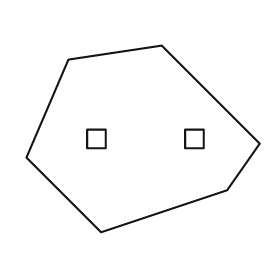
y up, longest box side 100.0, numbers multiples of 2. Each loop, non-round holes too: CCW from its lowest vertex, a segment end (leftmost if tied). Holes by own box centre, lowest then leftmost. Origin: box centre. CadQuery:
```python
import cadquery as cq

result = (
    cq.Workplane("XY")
    .moveTo(-18.0, -40.0)
    .lineTo(36.0, -22.0)
    .lineTo(50.0, -2.0)
    .lineTo(8.0, 40.0)
    .lineTo(-32.0, 34.0)
    .lineTo(-50.0, -8.0)
    .close()
    .moveTo(-24.0, -4.0)
    .lineTo(-16.0, -4.0)
    .lineTo(-16.0, 4.0)
    .lineTo(-24.0, 4.0)
    .close()
    .moveTo(18.0, -4.0)
    .lineTo(26.0, -4.0)
    .lineTo(26.0, 4.0)
    .lineTo(18.0, 4.0)
    .close()
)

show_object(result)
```